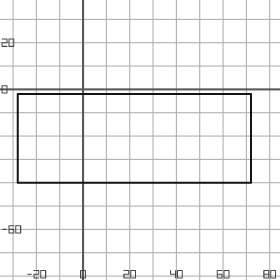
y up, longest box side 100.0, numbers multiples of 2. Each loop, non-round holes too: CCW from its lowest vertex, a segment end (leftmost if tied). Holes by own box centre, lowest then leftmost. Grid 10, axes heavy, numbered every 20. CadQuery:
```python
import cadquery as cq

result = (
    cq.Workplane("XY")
    .moveTo(-28.0, -40.0)
    .lineTo(72.0, -40.0)
    .lineTo(72.0, -2.0)
    .lineTo(-28.0, -2.0)
    .close()
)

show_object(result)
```